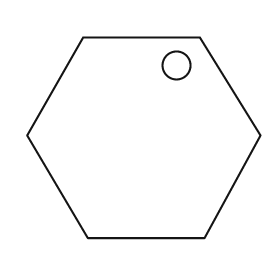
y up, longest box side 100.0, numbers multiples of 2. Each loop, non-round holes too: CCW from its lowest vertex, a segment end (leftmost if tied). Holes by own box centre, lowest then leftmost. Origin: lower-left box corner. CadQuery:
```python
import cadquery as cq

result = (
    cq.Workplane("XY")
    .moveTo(26.0, 0.0)
    .lineTo(76.0, 0.0)
    .lineTo(100.0, 44.0)
    .lineTo(74.0, 86.0)
    .lineTo(24.0, 86.0)
    .lineTo(0.0, 44.0)
    .close()
    .moveTo(64.0, 74.0)
    .circle(6.0)
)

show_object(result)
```